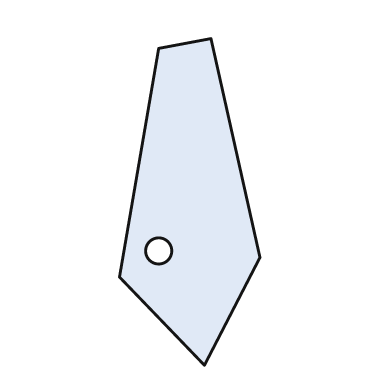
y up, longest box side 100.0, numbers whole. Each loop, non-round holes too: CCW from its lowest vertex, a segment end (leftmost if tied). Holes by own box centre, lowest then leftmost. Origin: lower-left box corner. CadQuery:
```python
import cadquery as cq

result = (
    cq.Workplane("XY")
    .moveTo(26.0, 0.0)
    .lineTo(43.0, 33.0)
    .lineTo(28.0, 100.0)
    .lineTo(12.0, 97.0)
    .lineTo(0.0, 27.0)
    .close()
    .moveTo(12.0, 35.0)
    .circle(4.0)
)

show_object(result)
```